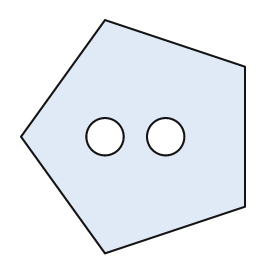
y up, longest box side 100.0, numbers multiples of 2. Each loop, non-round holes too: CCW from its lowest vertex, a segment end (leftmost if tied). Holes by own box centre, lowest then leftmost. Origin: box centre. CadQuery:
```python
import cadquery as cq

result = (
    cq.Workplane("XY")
    .moveTo(-12.0, -50.0)
    .lineTo(48.0, -30.0)
    .lineTo(48.0, 30.0)
    .lineTo(-12.0, 50.0)
    .lineTo(-48.0, 0.0)
    .close()
    .moveTo(-12.0, 0.0)
    .circle(8.0)
    .moveTo(14.0, 0.0)
    .circle(8.0)
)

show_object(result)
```